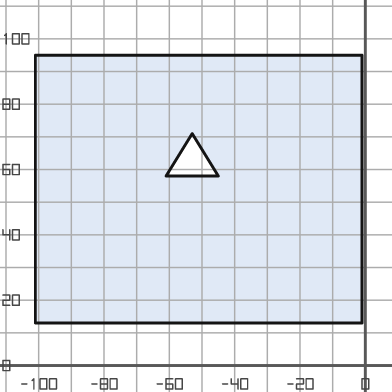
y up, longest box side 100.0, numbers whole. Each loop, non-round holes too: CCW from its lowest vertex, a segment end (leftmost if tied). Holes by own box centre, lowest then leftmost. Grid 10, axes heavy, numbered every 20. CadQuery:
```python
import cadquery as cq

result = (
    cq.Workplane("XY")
    .moveTo(-101.0, 13.0)
    .lineTo(-1.0, 13.0)
    .lineTo(-1.0, 95.0)
    .lineTo(-101.0, 95.0)
    .close()
    .moveTo(-61.0, 58.0)
    .lineTo(-45.0, 58.0)
    .lineTo(-53.0, 71.0)
    .close()
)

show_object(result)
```